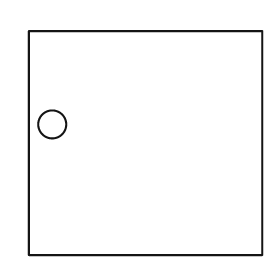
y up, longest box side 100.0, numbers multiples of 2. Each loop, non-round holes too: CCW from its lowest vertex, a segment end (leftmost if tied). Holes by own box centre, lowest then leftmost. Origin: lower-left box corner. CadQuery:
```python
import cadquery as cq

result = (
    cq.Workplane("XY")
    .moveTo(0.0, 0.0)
    .lineTo(100.0, 0.0)
    .lineTo(100.0, 96.0)
    .lineTo(0.0, 96.0)
    .close()
    .moveTo(10.0, 56.0)
    .circle(6.0)
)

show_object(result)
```